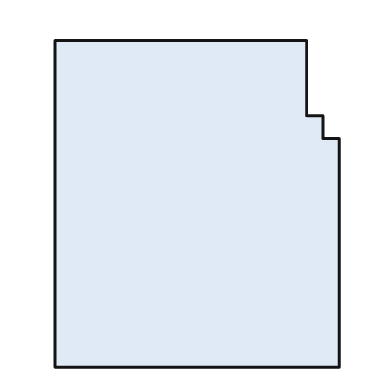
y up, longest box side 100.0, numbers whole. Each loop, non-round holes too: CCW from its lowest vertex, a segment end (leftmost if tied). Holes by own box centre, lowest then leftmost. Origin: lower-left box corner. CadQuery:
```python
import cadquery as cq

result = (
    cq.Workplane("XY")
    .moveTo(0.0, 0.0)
    .lineTo(87.0, 0.0)
    .lineTo(87.0, 70.0)
    .lineTo(82.0, 70.0)
    .lineTo(82.0, 77.0)
    .lineTo(77.0, 77.0)
    .lineTo(77.0, 100.0)
    .lineTo(0.0, 100.0)
    .close()
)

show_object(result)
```